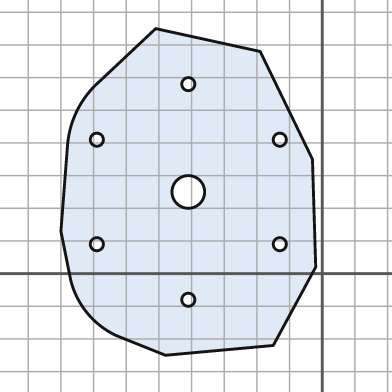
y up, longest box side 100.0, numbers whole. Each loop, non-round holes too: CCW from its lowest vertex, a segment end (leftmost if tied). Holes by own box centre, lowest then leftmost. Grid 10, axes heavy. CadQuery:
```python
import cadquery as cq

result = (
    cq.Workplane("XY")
    .moveTo(-48.0, -25.0)
    .lineTo(-15.0, -22.0)
    .lineTo(-2.0, 2.0)
    .lineTo(-3.0, 35.0)
    .lineTo(-19.0, 68.0)
    .lineTo(-51.0, 75.0)
    .lineTo(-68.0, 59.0)
    .threePointArc((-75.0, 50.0), (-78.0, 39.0))
    .lineTo(-80.0, 13.0)
    .lineTo(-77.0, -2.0)
    .threePointArc((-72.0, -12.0), (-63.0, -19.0))
    .close()
    .moveTo(-41.0, -8.0)
    .circle(2.0)
    .moveTo(-69.0, 9.0)
    .circle(2.0)
    .moveTo(-13.0, 9.0)
    .circle(2.0)
    .moveTo(-41.0, 25.0)
    .circle(5.0)
    .moveTo(-69.0, 41.0)
    .circle(2.0)
    .moveTo(-13.0, 41.0)
    .circle(2.0)
    .moveTo(-41.0, 58.0)
    .circle(2.0)
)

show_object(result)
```